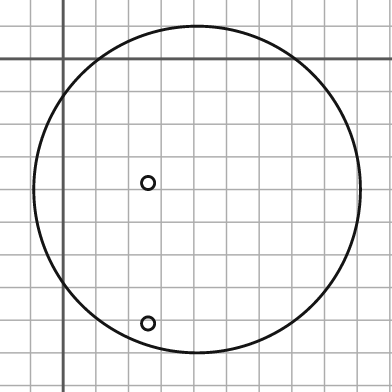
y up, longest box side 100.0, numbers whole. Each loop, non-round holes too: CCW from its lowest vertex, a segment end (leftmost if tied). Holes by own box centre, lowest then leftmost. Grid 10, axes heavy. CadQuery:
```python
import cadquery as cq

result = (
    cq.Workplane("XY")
    .moveTo(41.0, -40.0)
    .circle(50.0)
    .moveTo(26.0, -81.0)
    .circle(2.0)
    .moveTo(26.0, -38.0)
    .circle(2.0)
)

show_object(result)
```